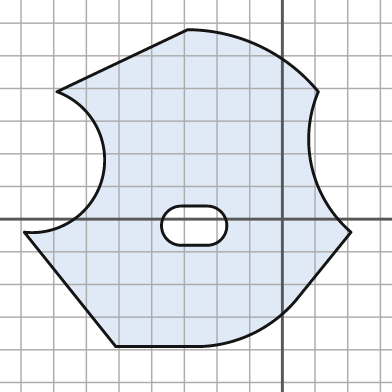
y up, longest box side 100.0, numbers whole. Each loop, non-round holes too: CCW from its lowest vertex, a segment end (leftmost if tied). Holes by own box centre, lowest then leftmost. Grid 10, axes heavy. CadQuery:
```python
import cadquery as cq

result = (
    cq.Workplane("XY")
    .moveTo(-51.0, -39.0)
    .lineTo(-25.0, -39.0)
    .threePointArc((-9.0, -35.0), (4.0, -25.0))
    .lineTo(21.0, -4.0)
    .threePointArc((9.0, 16.0), (11.0, 39.0))
    .threePointArc((-7.0, 53.0), (-29.0, 58.0))
    .lineTo(-69.0, 39.0)
    .threePointArc((-55.0, 13.0), (-79.0, -4.0))
    .close()
    .moveTo(-31.0, -8.0)
    .lineTo(-23.0, -8.0)
    .threePointArc((-17.0, -2.0), (-23.0, 4.0))
    .lineTo(-31.0, 4.0)
    .threePointArc((-37.0, -2.0), (-31.0, -8.0))
    .close()
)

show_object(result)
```